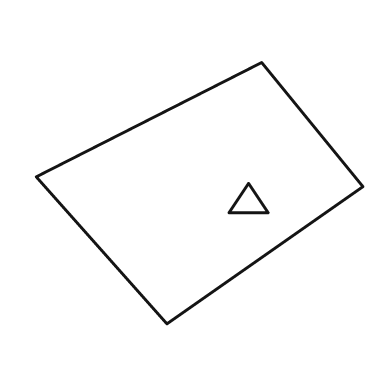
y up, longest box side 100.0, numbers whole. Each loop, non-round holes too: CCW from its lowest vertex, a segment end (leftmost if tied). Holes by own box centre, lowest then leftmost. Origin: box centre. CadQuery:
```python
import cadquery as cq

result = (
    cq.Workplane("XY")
    .moveTo(-10.0, -40.0)
    .lineTo(50.0, 2.0)
    .lineTo(19.0, 40.0)
    .lineTo(-50.0, 5.0)
    .close()
    .moveTo(9.0, -6.0)
    .lineTo(21.0, -6.0)
    .lineTo(15.0, 3.0)
    .close()
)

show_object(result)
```